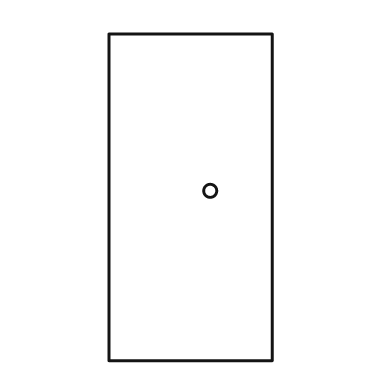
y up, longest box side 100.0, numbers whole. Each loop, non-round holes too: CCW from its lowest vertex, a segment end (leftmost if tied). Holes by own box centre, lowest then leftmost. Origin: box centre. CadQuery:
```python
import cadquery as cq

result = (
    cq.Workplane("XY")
    .moveTo(-25.0, -50.0)
    .lineTo(25.0, -50.0)
    .lineTo(25.0, 50.0)
    .lineTo(-25.0, 50.0)
    .close()
    .moveTo(6.0, 2.0)
    .circle(2.0)
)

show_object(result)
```